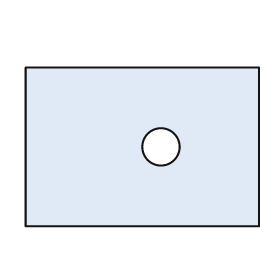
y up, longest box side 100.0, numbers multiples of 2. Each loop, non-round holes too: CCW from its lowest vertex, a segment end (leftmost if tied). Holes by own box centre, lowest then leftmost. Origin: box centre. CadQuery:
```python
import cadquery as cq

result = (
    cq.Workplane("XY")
    .moveTo(-50.0, -34.0)
    .lineTo(50.0, -34.0)
    .lineTo(50.0, 34.0)
    .lineTo(-50.0, 34.0)
    .close()
    .moveTo(8.0, 0.0)
    .circle(8.0)
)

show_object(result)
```